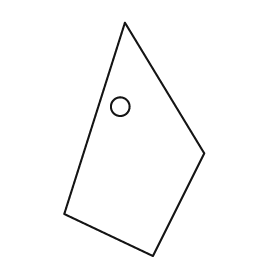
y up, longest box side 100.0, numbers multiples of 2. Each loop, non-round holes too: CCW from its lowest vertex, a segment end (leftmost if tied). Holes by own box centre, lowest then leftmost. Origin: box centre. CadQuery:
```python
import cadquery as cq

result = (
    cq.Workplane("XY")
    .moveTo(8.0, -50.0)
    .lineTo(30.0, -6.0)
    .lineTo(-4.0, 50.0)
    .lineTo(-30.0, -32.0)
    .close()
    .moveTo(-6.0, 14.0)
    .circle(4.0)
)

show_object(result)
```